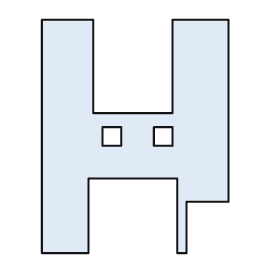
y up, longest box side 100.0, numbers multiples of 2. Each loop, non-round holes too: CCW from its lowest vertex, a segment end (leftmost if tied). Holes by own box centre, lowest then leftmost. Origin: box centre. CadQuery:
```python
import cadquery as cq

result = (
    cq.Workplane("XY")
    .moveTo(-40.0, -50.0)
    .lineTo(-20.0, -50.0)
    .lineTo(-20.0, -18.0)
    .lineTo(18.0, -18.0)
    .lineTo(18.0, -50.0)
    .lineTo(22.0, -50.0)
    .lineTo(22.0, -28.0)
    .lineTo(40.0, -28.0)
    .lineTo(40.0, 50.0)
    .lineTo(16.0, 50.0)
    .lineTo(16.0, 10.0)
    .lineTo(-18.0, 10.0)
    .lineTo(-18.0, 50.0)
    .lineTo(-40.0, 50.0)
    .close()
    .moveTo(-14.0, -4.0)
    .lineTo(-6.0, -4.0)
    .lineTo(-6.0, 4.0)
    .lineTo(-14.0, 4.0)
    .close()
    .moveTo(8.0, -4.0)
    .lineTo(16.0, -4.0)
    .lineTo(16.0, 4.0)
    .lineTo(8.0, 4.0)
    .close()
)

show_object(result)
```